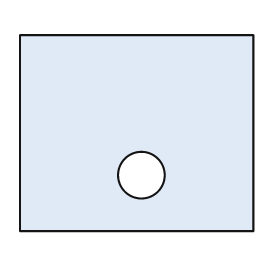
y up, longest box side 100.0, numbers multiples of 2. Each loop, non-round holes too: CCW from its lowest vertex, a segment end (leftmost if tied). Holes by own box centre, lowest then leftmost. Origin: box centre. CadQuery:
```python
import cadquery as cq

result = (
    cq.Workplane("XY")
    .moveTo(-50.0, -42.0)
    .lineTo(50.0, -42.0)
    .lineTo(50.0, 42.0)
    .lineTo(-50.0, 42.0)
    .close()
    .moveTo(2.0, -18.0)
    .circle(10.0)
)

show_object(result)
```